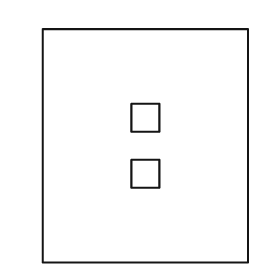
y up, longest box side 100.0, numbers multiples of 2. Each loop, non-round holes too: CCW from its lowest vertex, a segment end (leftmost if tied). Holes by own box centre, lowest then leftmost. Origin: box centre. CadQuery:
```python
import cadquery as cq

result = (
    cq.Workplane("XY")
    .moveTo(-44.0, -50.0)
    .lineTo(44.0, -50.0)
    .lineTo(44.0, 50.0)
    .lineTo(-44.0, 50.0)
    .close()
    .moveTo(-6.0, -18.0)
    .lineTo(6.0, -18.0)
    .lineTo(6.0, -6.0)
    .lineTo(-6.0, -6.0)
    .close()
    .moveTo(-6.0, 6.0)
    .lineTo(6.0, 6.0)
    .lineTo(6.0, 18.0)
    .lineTo(-6.0, 18.0)
    .close()
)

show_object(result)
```